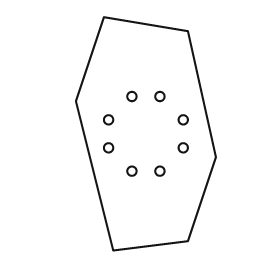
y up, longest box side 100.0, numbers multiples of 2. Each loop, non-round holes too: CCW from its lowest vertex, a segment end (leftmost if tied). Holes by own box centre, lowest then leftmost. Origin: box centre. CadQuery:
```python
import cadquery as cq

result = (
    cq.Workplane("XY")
    .moveTo(-14.0, -50.0)
    .lineTo(18.0, -46.0)
    .lineTo(30.0, -10.0)
    .lineTo(18.0, 44.0)
    .lineTo(-18.0, 50.0)
    .lineTo(-30.0, 14.0)
    .close()
    .moveTo(-6.0, -16.0)
    .circle(2.0)
    .moveTo(6.0, -16.0)
    .circle(2.0)
    .moveTo(-16.0, -6.0)
    .circle(2.0)
    .moveTo(16.0, -6.0)
    .circle(2.0)
    .moveTo(-16.0, 6.0)
    .circle(2.0)
    .moveTo(16.0, 6.0)
    .circle(2.0)
    .moveTo(-6.0, 16.0)
    .circle(2.0)
    .moveTo(6.0, 16.0)
    .circle(2.0)
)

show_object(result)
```